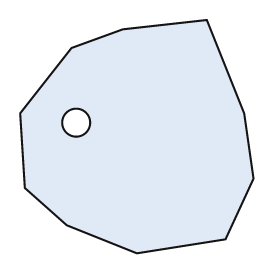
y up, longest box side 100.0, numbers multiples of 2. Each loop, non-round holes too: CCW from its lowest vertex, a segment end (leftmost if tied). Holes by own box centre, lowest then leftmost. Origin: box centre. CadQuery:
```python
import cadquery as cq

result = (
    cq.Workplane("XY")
    .moveTo(0.0, -50.0)
    .lineTo(38.0, -44.0)
    .lineTo(50.0, -18.0)
    .lineTo(46.0, 10.0)
    .lineTo(30.0, 50.0)
    .lineTo(-6.0, 46.0)
    .lineTo(-28.0, 38.0)
    .lineTo(-50.0, 10.0)
    .lineTo(-48.0, -22.0)
    .lineTo(-30.0, -38.0)
    .close()
    .moveTo(-26.0, 6.0)
    .circle(6.0)
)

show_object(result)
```